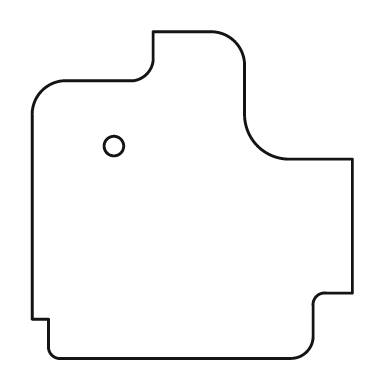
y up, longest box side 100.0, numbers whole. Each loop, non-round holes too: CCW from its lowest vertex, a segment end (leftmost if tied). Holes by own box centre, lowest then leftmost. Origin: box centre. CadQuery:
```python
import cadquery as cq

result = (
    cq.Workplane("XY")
    .moveTo(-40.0, -50.0)
    .lineTo(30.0, -50.0)
    .threePointArc((35.0, -48.0), (37.0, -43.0))
    .lineTo(37.0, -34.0)
    .threePointArc((38.0, -31.0), (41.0, -30.0))
    .lineTo(49.0, -30.0)
    .lineTo(49.0, 11.0)
    .lineTo(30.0, 11.0)
    .threePointArc((20.0, 15.0), (16.0, 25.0))
    .lineTo(16.0, 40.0)
    .threePointArc((13.0, 47.0), (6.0, 50.0))
    .lineTo(-12.0, 50.0)
    .lineTo(-12.0, 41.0)
    .threePointArc((-14.0, 37.0), (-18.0, 35.0))
    .lineTo(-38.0, 35.0)
    .threePointArc((-46.0, 32.0), (-49.0, 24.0))
    .lineTo(-49.0, -38.0)
    .lineTo(-44.0, -38.0)
    .lineTo(-44.0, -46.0)
    .threePointArc((-43.0, -49.0), (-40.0, -50.0))
    .close()
    .moveTo(-24.0, 15.0)
    .circle(3.0)
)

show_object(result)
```